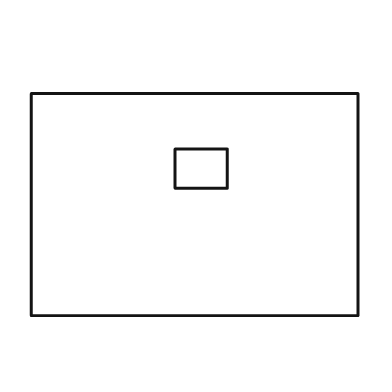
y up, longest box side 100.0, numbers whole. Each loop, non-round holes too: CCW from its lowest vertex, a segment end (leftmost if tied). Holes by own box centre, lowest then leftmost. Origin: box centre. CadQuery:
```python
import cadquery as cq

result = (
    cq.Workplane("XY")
    .moveTo(-50.0, -34.0)
    .lineTo(50.0, -34.0)
    .lineTo(50.0, 34.0)
    .lineTo(-50.0, 34.0)
    .close()
    .moveTo(-6.0, 5.0)
    .lineTo(10.0, 5.0)
    .lineTo(10.0, 17.0)
    .lineTo(-6.0, 17.0)
    .close()
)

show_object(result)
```